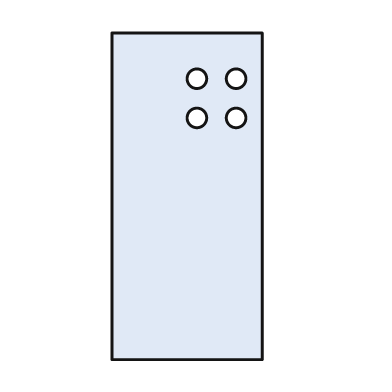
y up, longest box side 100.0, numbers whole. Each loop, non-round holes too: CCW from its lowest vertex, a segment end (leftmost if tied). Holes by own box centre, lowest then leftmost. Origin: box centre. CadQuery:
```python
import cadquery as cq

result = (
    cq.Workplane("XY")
    .moveTo(-23.0, -50.0)
    .lineTo(23.0, -50.0)
    .lineTo(23.0, 50.0)
    .lineTo(-23.0, 50.0)
    .close()
    .moveTo(3.0, 24.0)
    .circle(3.0)
    .moveTo(15.0, 24.0)
    .circle(3.0)
    .moveTo(3.0, 36.0)
    .circle(3.0)
    .moveTo(15.0, 36.0)
    .circle(3.0)
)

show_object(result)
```